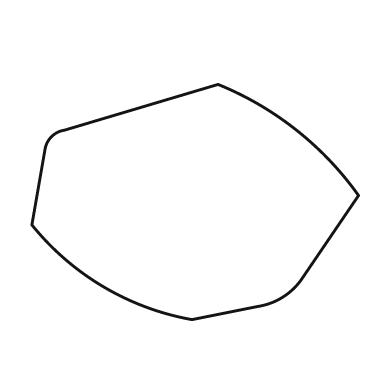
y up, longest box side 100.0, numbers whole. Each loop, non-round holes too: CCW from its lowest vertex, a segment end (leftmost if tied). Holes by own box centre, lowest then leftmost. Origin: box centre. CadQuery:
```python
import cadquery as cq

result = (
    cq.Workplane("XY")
    .moveTo(-1.0, -36.0)
    .lineTo(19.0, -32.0)
    .threePointArc((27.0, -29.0), (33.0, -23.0))
    .lineTo(50.0, 2.0)
    .threePointArc((31.0, 22.0), (7.0, 36.0))
    .lineTo(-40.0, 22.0)
    .threePointArc((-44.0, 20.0), (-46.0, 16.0))
    .lineTo(-50.0, -7.0)
    .threePointArc((-28.0, -26.0), (-1.0, -36.0))
    .close()
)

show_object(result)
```